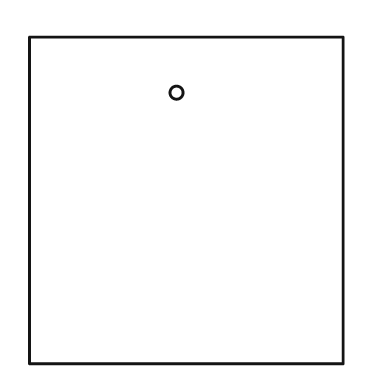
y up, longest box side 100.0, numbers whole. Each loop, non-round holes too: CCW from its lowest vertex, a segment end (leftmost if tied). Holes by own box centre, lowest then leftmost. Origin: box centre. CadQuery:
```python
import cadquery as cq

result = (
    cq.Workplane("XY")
    .moveTo(-48.0, -50.0)
    .lineTo(48.0, -50.0)
    .lineTo(48.0, 50.0)
    .lineTo(-48.0, 50.0)
    .close()
    .moveTo(-3.0, 33.0)
    .circle(2.0)
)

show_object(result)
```